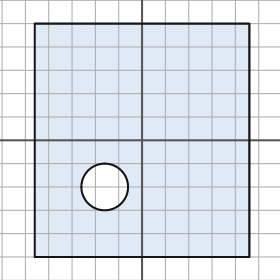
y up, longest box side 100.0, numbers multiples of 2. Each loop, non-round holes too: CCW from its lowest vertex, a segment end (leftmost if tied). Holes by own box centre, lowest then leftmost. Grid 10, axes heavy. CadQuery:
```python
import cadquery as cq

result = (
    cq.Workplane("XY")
    .moveTo(-46.0, -50.0)
    .lineTo(46.0, -50.0)
    .lineTo(46.0, 50.0)
    .lineTo(-46.0, 50.0)
    .close()
    .moveTo(-16.0, -20.0)
    .circle(10.0)
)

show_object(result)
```